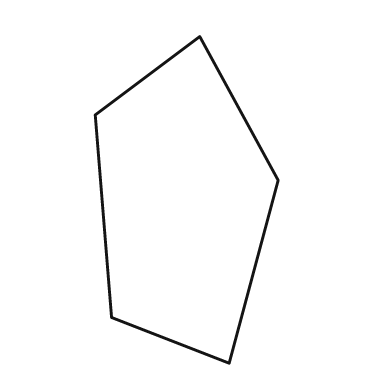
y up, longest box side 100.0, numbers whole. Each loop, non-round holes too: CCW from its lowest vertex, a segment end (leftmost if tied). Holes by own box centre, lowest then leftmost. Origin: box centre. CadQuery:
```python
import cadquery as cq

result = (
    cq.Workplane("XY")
    .moveTo(13.0, -50.0)
    .lineTo(28.0, 6.0)
    .lineTo(4.0, 50.0)
    .lineTo(-28.0, 26.0)
    .lineTo(-23.0, -36.0)
    .close()
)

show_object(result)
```